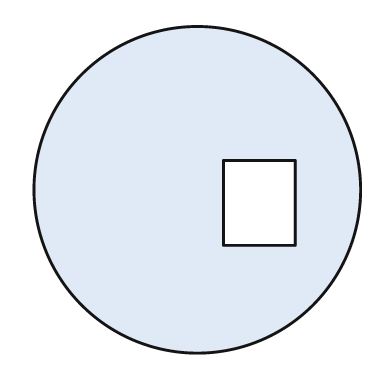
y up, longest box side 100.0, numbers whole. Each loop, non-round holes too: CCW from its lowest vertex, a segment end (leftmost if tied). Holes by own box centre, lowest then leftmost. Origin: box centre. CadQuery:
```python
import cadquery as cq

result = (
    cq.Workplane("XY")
    .moveTo(0.0, 0.0)
    .circle(50.0)
    .moveTo(8.0, -17.0)
    .lineTo(30.0, -17.0)
    .lineTo(30.0, 9.0)
    .lineTo(8.0, 9.0)
    .close()
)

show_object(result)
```